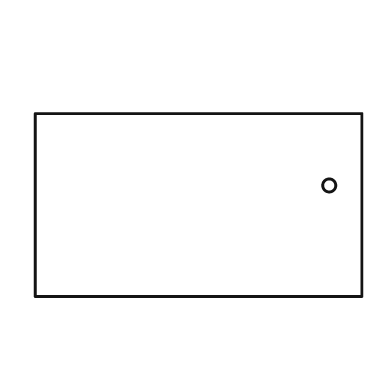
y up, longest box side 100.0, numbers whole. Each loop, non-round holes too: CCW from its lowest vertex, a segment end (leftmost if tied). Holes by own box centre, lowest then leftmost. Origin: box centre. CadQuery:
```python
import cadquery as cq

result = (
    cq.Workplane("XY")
    .moveTo(-50.0, -28.0)
    .lineTo(50.0, -28.0)
    .lineTo(50.0, 28.0)
    .lineTo(-50.0, 28.0)
    .close()
    .moveTo(40.0, 6.0)
    .circle(2.0)
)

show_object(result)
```